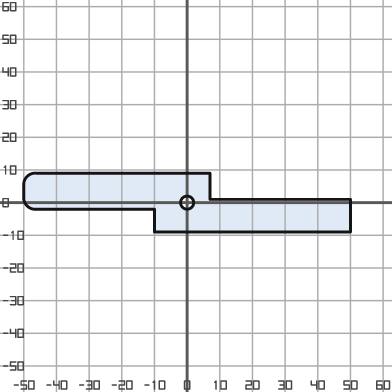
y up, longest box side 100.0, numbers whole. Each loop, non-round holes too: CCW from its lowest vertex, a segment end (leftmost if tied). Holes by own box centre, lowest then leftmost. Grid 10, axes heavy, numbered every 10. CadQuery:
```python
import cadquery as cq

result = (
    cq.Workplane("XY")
    .moveTo(-10.0, -9.0)
    .lineTo(50.0, -9.0)
    .lineTo(50.0, 1.0)
    .lineTo(7.0, 1.0)
    .lineTo(7.0, 9.0)
    .lineTo(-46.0, 9.0)
    .threePointArc((-49.0, 8.0), (-50.0, 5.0))
    .lineTo(-50.0, 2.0)
    .threePointArc((-49.0, -1.0), (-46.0, -2.0))
    .lineTo(-10.0, -2.0)
    .close()
    .moveTo(0.0, 0.0)
    .circle(2.0)
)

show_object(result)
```